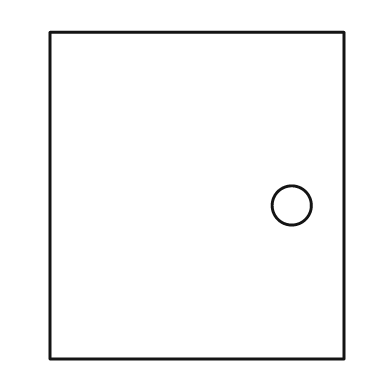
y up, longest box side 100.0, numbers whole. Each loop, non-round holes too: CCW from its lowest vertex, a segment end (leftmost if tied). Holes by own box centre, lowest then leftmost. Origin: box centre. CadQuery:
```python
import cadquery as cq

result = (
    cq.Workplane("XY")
    .moveTo(-45.0, -50.0)
    .lineTo(45.0, -50.0)
    .lineTo(45.0, 50.0)
    .lineTo(-45.0, 50.0)
    .close()
    .moveTo(29.0, -3.0)
    .circle(6.0)
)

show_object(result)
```